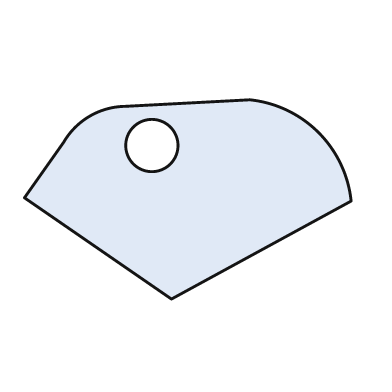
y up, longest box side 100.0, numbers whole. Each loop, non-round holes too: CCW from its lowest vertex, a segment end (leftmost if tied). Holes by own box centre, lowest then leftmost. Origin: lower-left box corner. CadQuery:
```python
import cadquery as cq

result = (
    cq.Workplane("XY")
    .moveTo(45.0, 0.0)
    .lineTo(100.0, 30.0)
    .threePointArc((90.0, 51.0), (69.0, 61.0))
    .lineTo(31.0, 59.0)
    .threePointArc((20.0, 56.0), (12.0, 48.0))
    .lineTo(0.0, 31.0)
    .close()
    .moveTo(39.0, 47.0)
    .circle(8.0)
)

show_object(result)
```